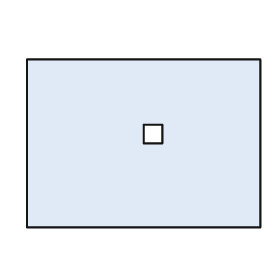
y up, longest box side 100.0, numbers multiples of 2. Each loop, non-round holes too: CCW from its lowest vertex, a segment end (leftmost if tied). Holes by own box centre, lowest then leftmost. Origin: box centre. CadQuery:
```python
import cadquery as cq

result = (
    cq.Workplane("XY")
    .moveTo(-50.0, -36.0)
    .lineTo(50.0, -36.0)
    .lineTo(50.0, 36.0)
    .lineTo(-50.0, 36.0)
    .close()
    .moveTo(0.0, 0.0)
    .lineTo(8.0, 0.0)
    .lineTo(8.0, 8.0)
    .lineTo(0.0, 8.0)
    .close()
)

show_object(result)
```